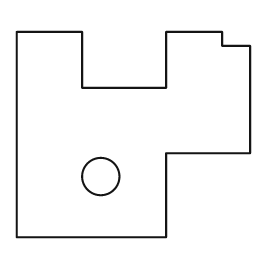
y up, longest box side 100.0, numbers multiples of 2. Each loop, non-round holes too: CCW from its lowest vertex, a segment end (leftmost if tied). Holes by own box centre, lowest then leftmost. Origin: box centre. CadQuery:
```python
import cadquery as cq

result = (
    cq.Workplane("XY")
    .moveTo(-50.0, -44.0)
    .lineTo(14.0, -44.0)
    .lineTo(14.0, -8.0)
    .lineTo(50.0, -8.0)
    .lineTo(50.0, 38.0)
    .lineTo(38.0, 38.0)
    .lineTo(38.0, 44.0)
    .lineTo(14.0, 44.0)
    .lineTo(14.0, 20.0)
    .lineTo(-22.0, 20.0)
    .lineTo(-22.0, 44.0)
    .lineTo(-50.0, 44.0)
    .close()
    .moveTo(-14.0, -18.0)
    .circle(8.0)
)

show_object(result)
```